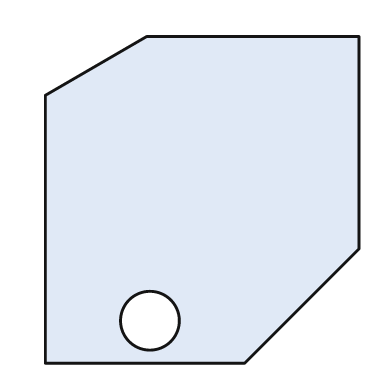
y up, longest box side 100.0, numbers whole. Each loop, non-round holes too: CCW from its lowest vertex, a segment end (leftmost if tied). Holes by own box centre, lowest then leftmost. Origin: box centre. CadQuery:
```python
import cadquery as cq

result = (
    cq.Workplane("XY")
    .moveTo(-48.0, -50.0)
    .lineTo(13.0, -50.0)
    .lineTo(48.0, -15.0)
    .lineTo(48.0, 50.0)
    .lineTo(-17.0, 50.0)
    .lineTo(-48.0, 32.0)
    .close()
    .moveTo(-16.0, -37.0)
    .circle(9.0)
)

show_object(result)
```